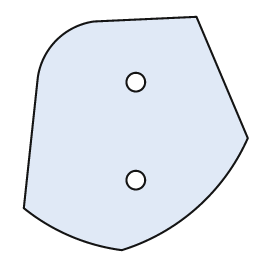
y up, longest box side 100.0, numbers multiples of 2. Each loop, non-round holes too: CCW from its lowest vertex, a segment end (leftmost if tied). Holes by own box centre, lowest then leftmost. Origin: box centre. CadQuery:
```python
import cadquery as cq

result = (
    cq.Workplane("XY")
    .moveTo(-6.0, -50.0)
    .threePointArc((26.0, -32.0), (48.0, -2.0))
    .lineTo(26.0, 50.0)
    .lineTo(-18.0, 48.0)
    .threePointArc((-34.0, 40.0), (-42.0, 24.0))
    .lineTo(-48.0, -32.0)
    .threePointArc((-28.0, -44.0), (-6.0, -50.0))
    .close()
    .moveTo(0.0, -20.0)
    .circle(4.0)
    .moveTo(0.0, 22.0)
    .circle(4.0)
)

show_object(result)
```